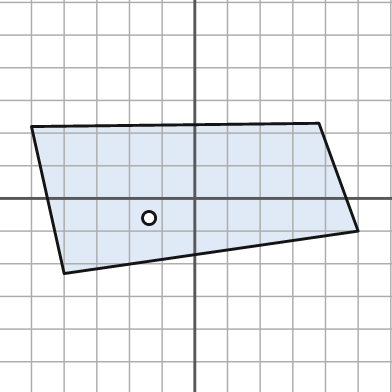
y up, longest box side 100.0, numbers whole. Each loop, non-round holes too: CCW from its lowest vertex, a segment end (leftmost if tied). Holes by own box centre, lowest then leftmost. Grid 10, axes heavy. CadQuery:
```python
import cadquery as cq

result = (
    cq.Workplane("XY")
    .moveTo(-40.0, -23.0)
    .lineTo(50.0, -10.0)
    .lineTo(38.0, 23.0)
    .lineTo(-50.0, 22.0)
    .close()
    .moveTo(-14.0, -6.0)
    .circle(2.0)
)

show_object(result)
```